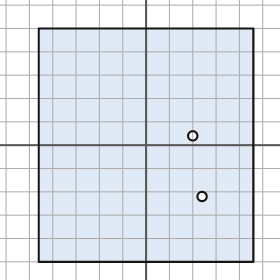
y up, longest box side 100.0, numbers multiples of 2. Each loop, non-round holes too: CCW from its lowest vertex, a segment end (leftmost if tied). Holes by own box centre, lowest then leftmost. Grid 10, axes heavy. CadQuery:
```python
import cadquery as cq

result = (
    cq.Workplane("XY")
    .moveTo(-46.0, -50.0)
    .lineTo(46.0, -50.0)
    .lineTo(46.0, 50.0)
    .lineTo(-46.0, 50.0)
    .close()
    .moveTo(24.0, -22.0)
    .circle(2.0)
    .moveTo(20.0, 4.0)
    .circle(2.0)
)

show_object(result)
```